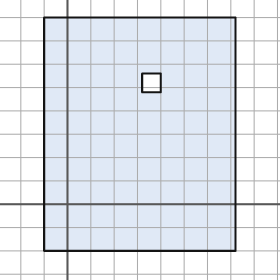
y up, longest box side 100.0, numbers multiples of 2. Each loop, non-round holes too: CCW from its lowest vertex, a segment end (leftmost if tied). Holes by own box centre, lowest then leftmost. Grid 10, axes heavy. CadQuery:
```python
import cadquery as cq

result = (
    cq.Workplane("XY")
    .moveTo(-10.0, -20.0)
    .lineTo(72.0, -20.0)
    .lineTo(72.0, 80.0)
    .lineTo(-10.0, 80.0)
    .close()
    .moveTo(32.0, 48.0)
    .lineTo(40.0, 48.0)
    .lineTo(40.0, 56.0)
    .lineTo(32.0, 56.0)
    .close()
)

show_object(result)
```